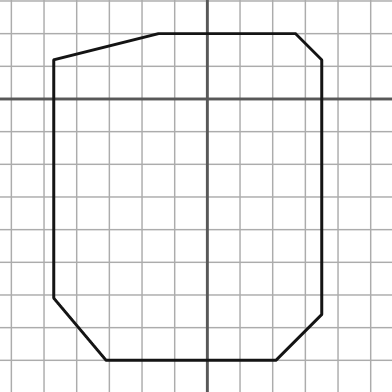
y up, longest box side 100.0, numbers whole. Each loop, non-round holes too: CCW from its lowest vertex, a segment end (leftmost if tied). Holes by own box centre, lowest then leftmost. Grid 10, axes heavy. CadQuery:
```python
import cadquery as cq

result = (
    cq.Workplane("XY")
    .moveTo(-31.0, -80.0)
    .lineTo(21.0, -80.0)
    .lineTo(35.0, -66.0)
    .lineTo(35.0, 12.0)
    .lineTo(27.0, 20.0)
    .lineTo(-15.0, 20.0)
    .lineTo(-47.0, 12.0)
    .lineTo(-47.0, -61.0)
    .close()
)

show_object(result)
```